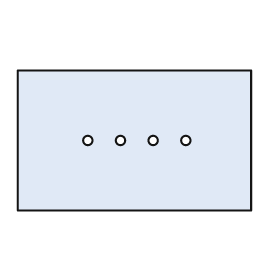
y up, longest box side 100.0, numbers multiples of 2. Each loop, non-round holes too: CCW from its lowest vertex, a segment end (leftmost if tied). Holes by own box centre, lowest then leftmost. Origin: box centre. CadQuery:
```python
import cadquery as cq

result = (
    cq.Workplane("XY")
    .moveTo(-50.0, -30.0)
    .lineTo(50.0, -30.0)
    .lineTo(50.0, 30.0)
    .lineTo(-50.0, 30.0)
    .close()
    .moveTo(-20.0, 0.0)
    .circle(2.0)
    .moveTo(-6.0, 0.0)
    .circle(2.0)
    .moveTo(8.0, 0.0)
    .circle(2.0)
    .moveTo(22.0, 0.0)
    .circle(2.0)
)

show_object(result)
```